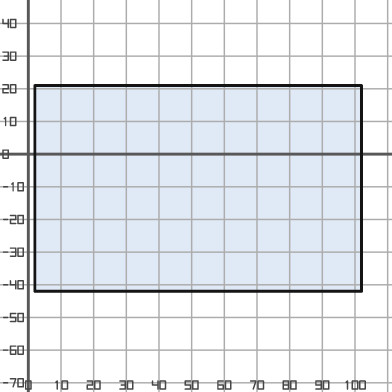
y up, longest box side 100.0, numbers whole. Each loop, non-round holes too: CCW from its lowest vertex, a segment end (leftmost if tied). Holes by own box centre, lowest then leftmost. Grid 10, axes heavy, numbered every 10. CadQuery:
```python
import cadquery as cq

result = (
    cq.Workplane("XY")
    .moveTo(2.0, -42.0)
    .lineTo(102.0, -42.0)
    .lineTo(102.0, 21.0)
    .lineTo(2.0, 21.0)
    .close()
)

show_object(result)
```